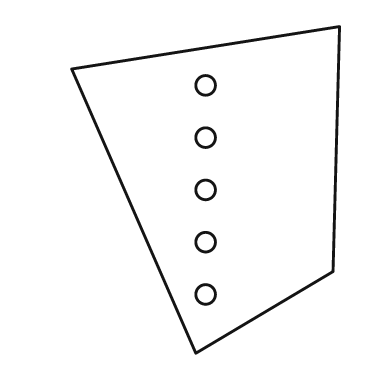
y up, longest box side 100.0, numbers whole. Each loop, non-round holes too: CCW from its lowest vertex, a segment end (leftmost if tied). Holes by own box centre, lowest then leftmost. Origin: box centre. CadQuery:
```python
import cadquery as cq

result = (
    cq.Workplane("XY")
    .moveTo(-3.0, -50.0)
    .lineTo(39.0, -25.0)
    .lineTo(41.0, 50.0)
    .lineTo(-41.0, 37.0)
    .close()
    .moveTo(0.0, -32.0)
    .circle(3.0)
    .moveTo(0.0, -16.0)
    .circle(3.0)
    .moveTo(0.0, 0.0)
    .circle(3.0)
    .moveTo(0.0, 16.0)
    .circle(3.0)
    .moveTo(0.0, 32.0)
    .circle(3.0)
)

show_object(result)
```